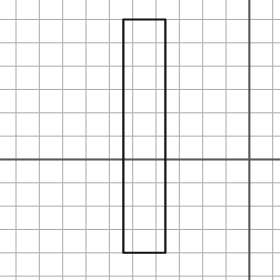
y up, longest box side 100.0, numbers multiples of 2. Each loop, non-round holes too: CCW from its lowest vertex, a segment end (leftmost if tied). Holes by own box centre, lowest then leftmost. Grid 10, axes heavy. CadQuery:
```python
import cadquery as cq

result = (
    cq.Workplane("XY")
    .moveTo(-54.0, -40.0)
    .lineTo(-36.0, -40.0)
    .lineTo(-36.0, 60.0)
    .lineTo(-54.0, 60.0)
    .close()
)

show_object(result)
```